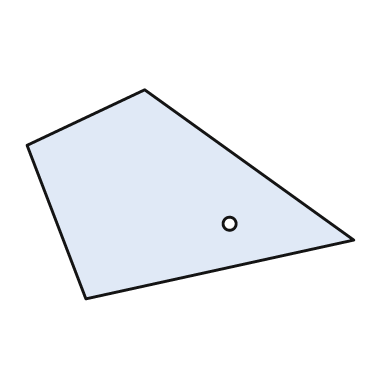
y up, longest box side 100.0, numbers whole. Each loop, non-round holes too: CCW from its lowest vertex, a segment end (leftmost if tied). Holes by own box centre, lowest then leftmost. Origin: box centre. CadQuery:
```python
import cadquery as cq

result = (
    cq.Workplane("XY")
    .moveTo(-32.0, -32.0)
    .lineTo(50.0, -14.0)
    .lineTo(-14.0, 32.0)
    .lineTo(-50.0, 15.0)
    .close()
    .moveTo(12.0, -9.0)
    .circle(2.0)
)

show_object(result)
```